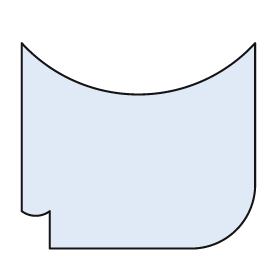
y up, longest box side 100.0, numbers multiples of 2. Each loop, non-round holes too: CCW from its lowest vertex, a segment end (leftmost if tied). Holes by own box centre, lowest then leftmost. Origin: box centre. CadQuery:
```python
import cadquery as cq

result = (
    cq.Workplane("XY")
    .moveTo(-38.0, -44.0)
    .lineTo(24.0, -44.0)
    .threePointArc((42.0, -36.0), (50.0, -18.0))
    .lineTo(50.0, 44.0)
    .threePointArc((0.0, 22.0), (-50.0, 44.0))
    .lineTo(-50.0, -28.0)
    .threePointArc((-44.0, -30.0), (-38.0, -28.0))
    .close()
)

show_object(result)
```